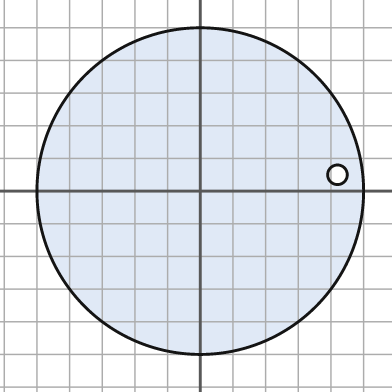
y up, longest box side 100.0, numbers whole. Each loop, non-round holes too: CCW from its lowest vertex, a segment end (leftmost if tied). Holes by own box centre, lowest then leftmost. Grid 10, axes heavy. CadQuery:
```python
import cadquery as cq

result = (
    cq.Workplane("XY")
    .moveTo(0.0, 0.0)
    .circle(50.0)
    .moveTo(42.0, 5.0)
    .circle(3.0)
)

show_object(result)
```